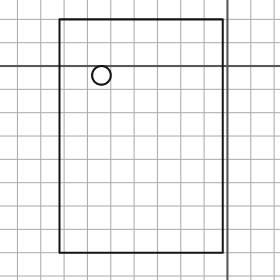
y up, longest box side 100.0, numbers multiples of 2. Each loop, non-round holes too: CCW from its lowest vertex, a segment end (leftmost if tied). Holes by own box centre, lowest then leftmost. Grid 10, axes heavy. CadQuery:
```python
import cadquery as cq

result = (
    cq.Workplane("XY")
    .moveTo(-72.0, -80.0)
    .lineTo(-2.0, -80.0)
    .lineTo(-2.0, 20.0)
    .lineTo(-72.0, 20.0)
    .close()
    .moveTo(-54.0, -4.0)
    .circle(4.0)
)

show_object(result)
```